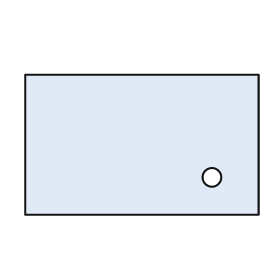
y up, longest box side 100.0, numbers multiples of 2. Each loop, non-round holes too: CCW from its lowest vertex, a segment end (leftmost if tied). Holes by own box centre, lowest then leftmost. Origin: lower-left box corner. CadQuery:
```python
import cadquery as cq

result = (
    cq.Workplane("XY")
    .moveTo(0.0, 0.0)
    .lineTo(100.0, 0.0)
    .lineTo(100.0, 60.0)
    .lineTo(0.0, 60.0)
    .close()
    .moveTo(80.0, 16.0)
    .circle(4.0)
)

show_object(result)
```